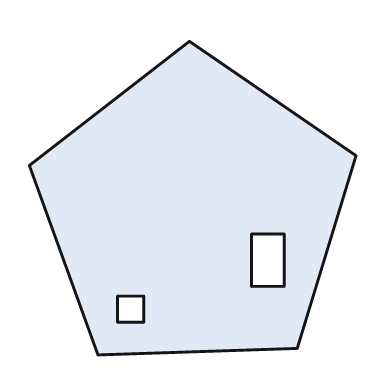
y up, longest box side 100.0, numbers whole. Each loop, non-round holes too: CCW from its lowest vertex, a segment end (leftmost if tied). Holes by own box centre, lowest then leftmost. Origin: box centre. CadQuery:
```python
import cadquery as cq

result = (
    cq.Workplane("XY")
    .moveTo(-29.0, -48.0)
    .lineTo(32.0, -46.0)
    .lineTo(50.0, 13.0)
    .lineTo(-1.0, 48.0)
    .lineTo(-50.0, 10.0)
    .close()
    .moveTo(-23.0, -38.0)
    .lineTo(-15.0, -38.0)
    .lineTo(-15.0, -30.0)
    .lineTo(-23.0, -30.0)
    .close()
    .moveTo(18.0, -27.0)
    .lineTo(28.0, -27.0)
    .lineTo(28.0, -11.0)
    .lineTo(18.0, -11.0)
    .close()
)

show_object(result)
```